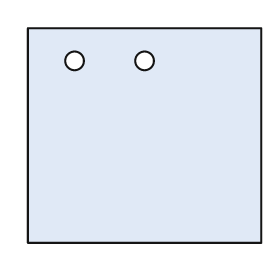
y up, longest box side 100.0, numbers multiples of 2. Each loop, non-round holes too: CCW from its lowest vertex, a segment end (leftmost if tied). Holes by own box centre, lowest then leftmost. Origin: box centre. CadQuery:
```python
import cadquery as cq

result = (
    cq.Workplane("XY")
    .moveTo(-50.0, -46.0)
    .lineTo(50.0, -46.0)
    .lineTo(50.0, 46.0)
    .lineTo(-50.0, 46.0)
    .close()
    .moveTo(-30.0, 32.0)
    .circle(4.0)
    .moveTo(0.0, 32.0)
    .circle(4.0)
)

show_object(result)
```